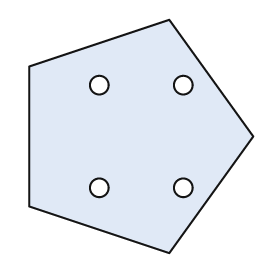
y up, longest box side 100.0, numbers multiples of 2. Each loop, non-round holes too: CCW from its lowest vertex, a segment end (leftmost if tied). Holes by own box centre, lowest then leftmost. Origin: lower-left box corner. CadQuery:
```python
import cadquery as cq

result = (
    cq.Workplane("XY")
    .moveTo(60.0, 0.0)
    .lineTo(96.0, 50.0)
    .lineTo(60.0, 100.0)
    .lineTo(0.0, 80.0)
    .lineTo(0.0, 20.0)
    .close()
    .moveTo(30.0, 28.0)
    .circle(4.0)
    .moveTo(66.0, 28.0)
    .circle(4.0)
    .moveTo(30.0, 72.0)
    .circle(4.0)
    .moveTo(66.0, 72.0)
    .circle(4.0)
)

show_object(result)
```